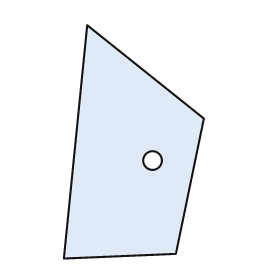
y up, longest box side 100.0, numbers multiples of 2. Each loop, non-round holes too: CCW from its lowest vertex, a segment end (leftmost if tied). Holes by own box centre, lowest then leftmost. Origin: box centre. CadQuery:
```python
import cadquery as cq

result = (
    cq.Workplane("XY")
    .moveTo(-30.0, -50.0)
    .lineTo(18.0, -48.0)
    .lineTo(30.0, 10.0)
    .lineTo(-20.0, 50.0)
    .close()
    .moveTo(8.0, -8.0)
    .circle(4.0)
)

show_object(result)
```